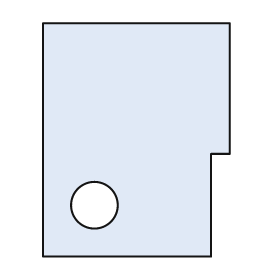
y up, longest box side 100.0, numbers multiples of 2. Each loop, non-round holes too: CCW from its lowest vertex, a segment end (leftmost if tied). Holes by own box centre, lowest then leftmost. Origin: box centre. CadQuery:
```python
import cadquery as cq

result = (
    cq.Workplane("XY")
    .moveTo(-40.0, -50.0)
    .lineTo(32.0, -50.0)
    .lineTo(32.0, -6.0)
    .lineTo(40.0, -6.0)
    .lineTo(40.0, 50.0)
    .lineTo(-40.0, 50.0)
    .close()
    .moveTo(-18.0, -28.0)
    .circle(10.0)
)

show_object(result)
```